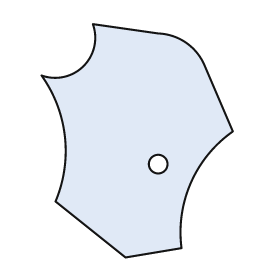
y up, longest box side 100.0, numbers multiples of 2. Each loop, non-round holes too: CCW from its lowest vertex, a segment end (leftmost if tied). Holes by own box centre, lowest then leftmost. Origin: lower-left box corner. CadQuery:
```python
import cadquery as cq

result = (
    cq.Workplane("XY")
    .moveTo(36.0, 0.0)
    .lineTo(60.0, 4.0)
    .threePointArc((64.0, 32.0), (82.0, 54.0))
    .lineTo(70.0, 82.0)
    .threePointArc((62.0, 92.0), (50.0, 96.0))
    .lineTo(22.0, 100.0)
    .threePointArc((18.0, 82.0), (0.0, 78.0))
    .threePointArc((10.0, 52.0), (6.0, 24.0))
    .close()
    .moveTo(50.0, 40.0)
    .circle(4.0)
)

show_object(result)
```